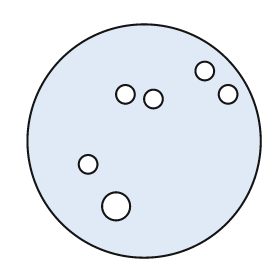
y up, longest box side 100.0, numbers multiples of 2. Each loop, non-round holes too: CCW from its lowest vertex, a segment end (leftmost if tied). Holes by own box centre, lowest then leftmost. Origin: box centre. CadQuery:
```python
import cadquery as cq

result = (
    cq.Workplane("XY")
    .moveTo(0.0, 0.0)
    .circle(50.0)
    .moveTo(-12.0, -28.0)
    .circle(6.0)
    .moveTo(-24.0, -10.0)
    .circle(4.0)
    .moveTo(4.0, 18.0)
    .circle(4.0)
    .moveTo(-8.0, 20.0)
    .circle(4.0)
    .moveTo(36.0, 20.0)
    .circle(4.0)
    .moveTo(26.0, 30.0)
    .circle(4.0)
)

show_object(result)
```